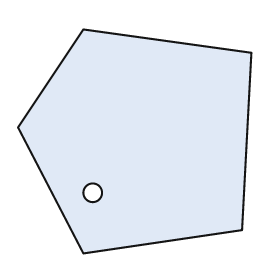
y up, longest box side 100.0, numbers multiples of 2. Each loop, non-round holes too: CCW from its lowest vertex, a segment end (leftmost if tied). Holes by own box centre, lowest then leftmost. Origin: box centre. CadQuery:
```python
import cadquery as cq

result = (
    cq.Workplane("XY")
    .moveTo(-22.0, -48.0)
    .lineTo(46.0, -38.0)
    .lineTo(50.0, 38.0)
    .lineTo(-22.0, 48.0)
    .lineTo(-50.0, 6.0)
    .close()
    .moveTo(-18.0, -22.0)
    .circle(4.0)
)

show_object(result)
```